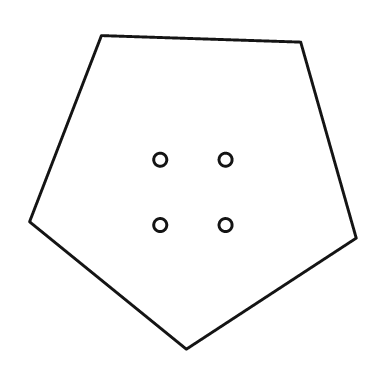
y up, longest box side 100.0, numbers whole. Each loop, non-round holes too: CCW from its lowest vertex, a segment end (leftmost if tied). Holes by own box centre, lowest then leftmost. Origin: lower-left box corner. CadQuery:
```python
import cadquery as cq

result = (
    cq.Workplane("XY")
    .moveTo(48.0, 0.0)
    .lineTo(100.0, 34.0)
    .lineTo(83.0, 94.0)
    .lineTo(22.0, 96.0)
    .lineTo(0.0, 39.0)
    .close()
    .moveTo(40.0, 38.0)
    .circle(2.0)
    .moveTo(60.0, 38.0)
    .circle(2.0)
    .moveTo(40.0, 58.0)
    .circle(2.0)
    .moveTo(60.0, 58.0)
    .circle(2.0)
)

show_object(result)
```